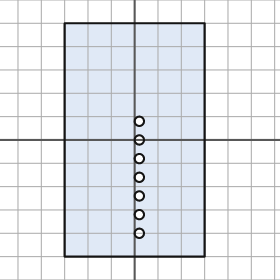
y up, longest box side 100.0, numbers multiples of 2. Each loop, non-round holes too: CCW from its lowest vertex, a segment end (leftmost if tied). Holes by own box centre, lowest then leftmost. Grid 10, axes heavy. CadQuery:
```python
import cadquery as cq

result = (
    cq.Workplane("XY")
    .moveTo(-30.0, -50.0)
    .lineTo(30.0, -50.0)
    .lineTo(30.0, 50.0)
    .lineTo(-30.0, 50.0)
    .close()
    .moveTo(2.0, -40.0)
    .circle(2.0)
    .moveTo(2.0, -32.0)
    .circle(2.0)
    .moveTo(2.0, -24.0)
    .circle(2.0)
    .moveTo(2.0, -16.0)
    .circle(2.0)
    .moveTo(2.0, -8.0)
    .circle(2.0)
    .moveTo(2.0, 0.0)
    .circle(2.0)
    .moveTo(2.0, 8.0)
    .circle(2.0)
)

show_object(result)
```